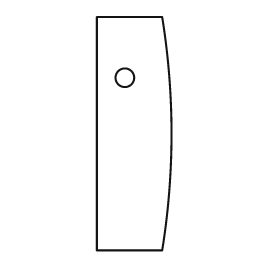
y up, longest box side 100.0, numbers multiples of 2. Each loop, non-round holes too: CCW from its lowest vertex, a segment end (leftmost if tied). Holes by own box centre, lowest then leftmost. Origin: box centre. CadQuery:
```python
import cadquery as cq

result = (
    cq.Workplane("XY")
    .moveTo(-16.0, -50.0)
    .lineTo(12.0, -50.0)
    .threePointArc((16.0, 0.0), (12.0, 50.0))
    .lineTo(-16.0, 50.0)
    .close()
    .moveTo(-4.0, 24.0)
    .circle(4.0)
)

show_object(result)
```